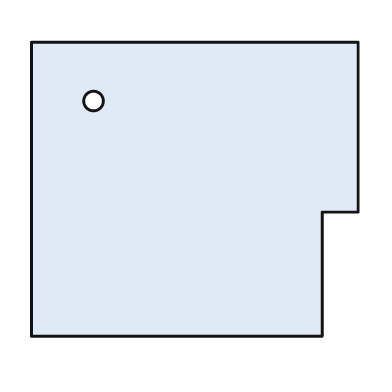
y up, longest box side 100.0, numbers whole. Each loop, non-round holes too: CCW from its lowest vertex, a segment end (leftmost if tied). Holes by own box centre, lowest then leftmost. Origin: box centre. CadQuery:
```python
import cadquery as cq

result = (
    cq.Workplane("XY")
    .moveTo(-50.0, -45.0)
    .lineTo(39.0, -45.0)
    .lineTo(39.0, -7.0)
    .lineTo(50.0, -7.0)
    .lineTo(50.0, 45.0)
    .lineTo(-50.0, 45.0)
    .close()
    .moveTo(-31.0, 27.0)
    .circle(3.0)
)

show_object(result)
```